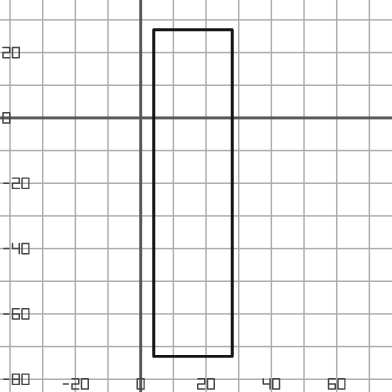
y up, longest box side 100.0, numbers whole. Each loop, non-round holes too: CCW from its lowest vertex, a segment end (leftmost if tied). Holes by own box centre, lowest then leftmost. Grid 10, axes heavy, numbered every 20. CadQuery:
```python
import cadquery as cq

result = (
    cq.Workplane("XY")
    .moveTo(4.0, -73.0)
    .lineTo(28.0, -73.0)
    .lineTo(28.0, 27.0)
    .lineTo(4.0, 27.0)
    .close()
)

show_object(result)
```